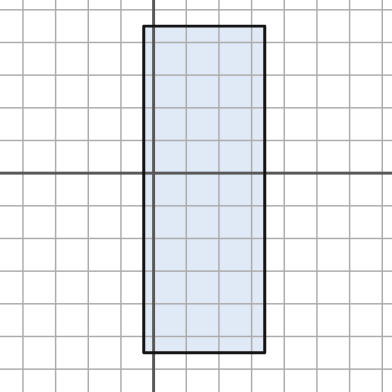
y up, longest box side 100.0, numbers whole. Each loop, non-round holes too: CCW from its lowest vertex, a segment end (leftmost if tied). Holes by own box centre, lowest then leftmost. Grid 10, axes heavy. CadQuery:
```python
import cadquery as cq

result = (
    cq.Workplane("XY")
    .moveTo(-3.0, -55.0)
    .lineTo(34.0, -55.0)
    .lineTo(34.0, 45.0)
    .lineTo(-3.0, 45.0)
    .close()
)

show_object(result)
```